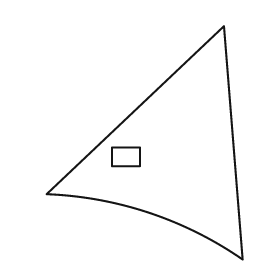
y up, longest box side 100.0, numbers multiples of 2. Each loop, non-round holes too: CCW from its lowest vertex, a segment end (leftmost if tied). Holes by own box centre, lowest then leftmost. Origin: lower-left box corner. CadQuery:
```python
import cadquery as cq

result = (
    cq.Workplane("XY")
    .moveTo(84.0, 0.0)
    .lineTo(76.0, 100.0)
    .lineTo(0.0, 28.0)
    .threePointArc((44.0, 20.0), (84.0, 0.0))
    .close()
    .moveTo(28.0, 40.0)
    .lineTo(40.0, 40.0)
    .lineTo(40.0, 48.0)
    .lineTo(28.0, 48.0)
    .close()
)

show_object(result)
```